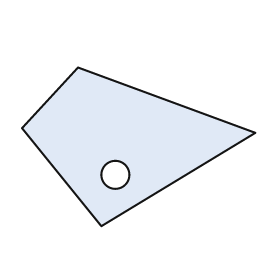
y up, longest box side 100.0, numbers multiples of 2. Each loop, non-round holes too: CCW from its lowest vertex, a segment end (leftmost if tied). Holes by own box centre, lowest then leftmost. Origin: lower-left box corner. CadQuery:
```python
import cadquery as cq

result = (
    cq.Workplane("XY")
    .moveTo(34.0, 0.0)
    .lineTo(100.0, 40.0)
    .lineTo(24.0, 68.0)
    .lineTo(0.0, 42.0)
    .close()
    .moveTo(40.0, 22.0)
    .circle(6.0)
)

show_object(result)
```